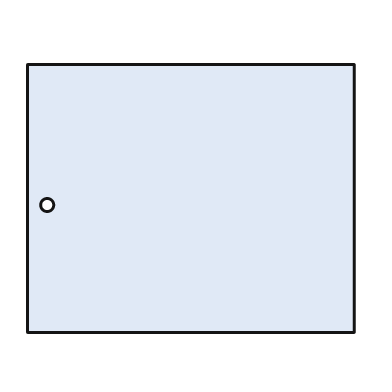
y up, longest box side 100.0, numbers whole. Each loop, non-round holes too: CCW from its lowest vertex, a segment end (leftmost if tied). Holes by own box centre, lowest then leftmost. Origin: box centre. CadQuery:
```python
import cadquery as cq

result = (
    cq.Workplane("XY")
    .moveTo(-50.0, -41.0)
    .lineTo(50.0, -41.0)
    .lineTo(50.0, 41.0)
    .lineTo(-50.0, 41.0)
    .close()
    .moveTo(-44.0, -2.0)
    .circle(2.0)
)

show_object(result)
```